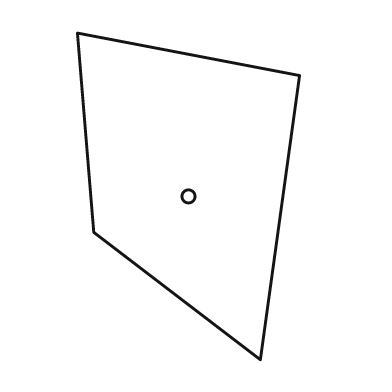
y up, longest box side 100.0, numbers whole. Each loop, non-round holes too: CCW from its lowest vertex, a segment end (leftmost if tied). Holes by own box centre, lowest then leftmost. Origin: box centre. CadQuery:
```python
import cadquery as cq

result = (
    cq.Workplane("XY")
    .moveTo(22.0, -50.0)
    .lineTo(34.0, 37.0)
    .lineTo(-34.0, 50.0)
    .lineTo(-29.0, -11.0)
    .close()
    .moveTo(0.0, 0.0)
    .circle(2.0)
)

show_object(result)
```